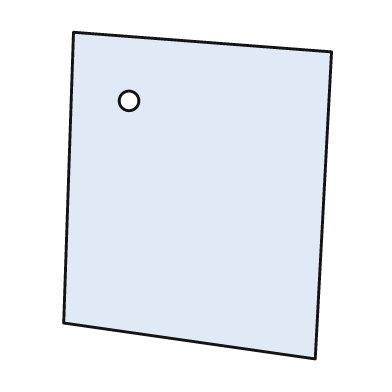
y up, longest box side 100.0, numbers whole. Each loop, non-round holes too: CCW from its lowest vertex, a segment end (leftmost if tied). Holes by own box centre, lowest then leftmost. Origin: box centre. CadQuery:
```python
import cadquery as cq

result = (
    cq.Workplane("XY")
    .moveTo(36.0, -50.0)
    .lineTo(41.0, 44.0)
    .lineTo(-38.0, 50.0)
    .lineTo(-41.0, -39.0)
    .close()
    .moveTo(-21.0, 29.0)
    .circle(3.0)
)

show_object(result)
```